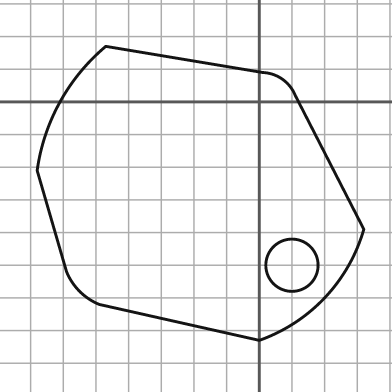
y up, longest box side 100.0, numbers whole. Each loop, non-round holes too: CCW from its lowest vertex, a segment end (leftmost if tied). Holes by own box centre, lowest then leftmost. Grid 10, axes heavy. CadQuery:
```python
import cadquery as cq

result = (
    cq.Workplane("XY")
    .moveTo(0.0, -73.0)
    .threePointArc((20.0, -60.0), (32.0, -39.0))
    .lineTo(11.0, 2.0)
    .threePointArc((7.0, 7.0), (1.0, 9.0))
    .lineTo(-47.0, 17.0)
    .threePointArc((-61.0, 0.0), (-68.0, -21.0))
    .lineTo(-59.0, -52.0)
    .threePointArc((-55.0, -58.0), (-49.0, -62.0))
    .close()
    .moveTo(10.0, -50.0)
    .circle(8.0)
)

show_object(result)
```